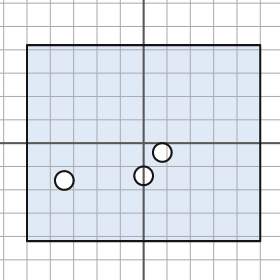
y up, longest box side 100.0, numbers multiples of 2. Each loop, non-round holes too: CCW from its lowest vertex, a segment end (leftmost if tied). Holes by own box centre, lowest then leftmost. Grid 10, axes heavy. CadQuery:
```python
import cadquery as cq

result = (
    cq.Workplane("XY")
    .moveTo(-50.0, -42.0)
    .lineTo(50.0, -42.0)
    .lineTo(50.0, 42.0)
    .lineTo(-50.0, 42.0)
    .close()
    .moveTo(-34.0, -16.0)
    .circle(4.0)
    .moveTo(0.0, -14.0)
    .circle(4.0)
    .moveTo(8.0, -4.0)
    .circle(4.0)
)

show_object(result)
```